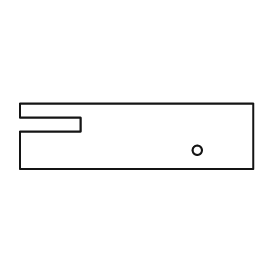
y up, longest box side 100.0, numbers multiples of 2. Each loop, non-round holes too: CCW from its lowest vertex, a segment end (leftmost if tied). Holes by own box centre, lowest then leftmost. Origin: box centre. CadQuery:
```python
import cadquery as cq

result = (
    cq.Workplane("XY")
    .moveTo(-50.0, -14.0)
    .lineTo(50.0, -14.0)
    .lineTo(50.0, 14.0)
    .lineTo(-50.0, 14.0)
    .lineTo(-50.0, 8.0)
    .lineTo(-24.0, 8.0)
    .lineTo(-24.0, 2.0)
    .lineTo(-50.0, 2.0)
    .close()
    .moveTo(26.0, -6.0)
    .circle(2.0)
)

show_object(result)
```